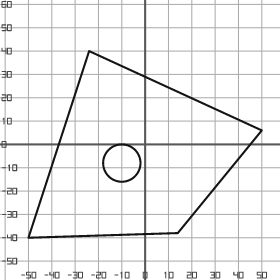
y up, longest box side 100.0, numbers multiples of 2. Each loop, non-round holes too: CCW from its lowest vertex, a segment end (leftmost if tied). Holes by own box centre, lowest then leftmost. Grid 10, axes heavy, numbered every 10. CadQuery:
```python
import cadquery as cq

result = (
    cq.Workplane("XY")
    .moveTo(-50.0, -40.0)
    .lineTo(14.0, -38.0)
    .lineTo(50.0, 6.0)
    .lineTo(-24.0, 40.0)
    .close()
    .moveTo(-10.0, -8.0)
    .circle(8.0)
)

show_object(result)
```